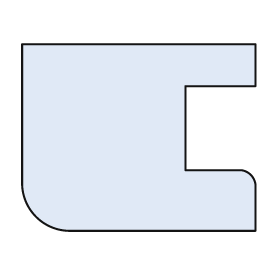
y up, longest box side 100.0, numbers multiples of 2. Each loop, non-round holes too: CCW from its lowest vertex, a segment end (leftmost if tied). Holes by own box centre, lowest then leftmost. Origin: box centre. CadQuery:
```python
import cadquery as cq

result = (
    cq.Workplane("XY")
    .moveTo(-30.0, -40.0)
    .lineTo(50.0, -40.0)
    .lineTo(50.0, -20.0)
    .threePointArc((48.0, -16.0), (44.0, -14.0))
    .lineTo(20.0, -14.0)
    .lineTo(20.0, 22.0)
    .lineTo(50.0, 22.0)
    .lineTo(50.0, 40.0)
    .lineTo(-50.0, 40.0)
    .lineTo(-50.0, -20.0)
    .threePointArc((-44.0, -34.0), (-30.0, -40.0))
    .close()
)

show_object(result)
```